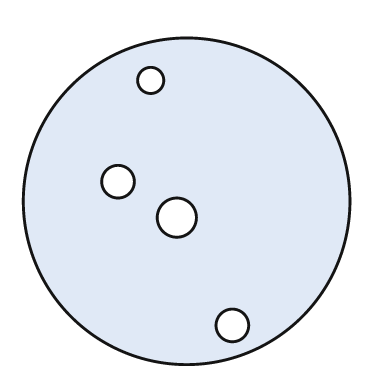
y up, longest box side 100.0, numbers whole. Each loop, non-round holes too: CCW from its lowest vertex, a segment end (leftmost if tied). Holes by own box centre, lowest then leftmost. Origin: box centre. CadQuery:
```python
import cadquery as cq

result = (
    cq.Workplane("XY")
    .moveTo(0.0, 0.0)
    .circle(50.0)
    .moveTo(14.0, -38.0)
    .circle(5.0)
    .moveTo(-3.0, -5.0)
    .circle(6.0)
    .moveTo(-21.0, 6.0)
    .circle(5.0)
    .moveTo(-11.0, 37.0)
    .circle(4.0)
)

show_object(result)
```